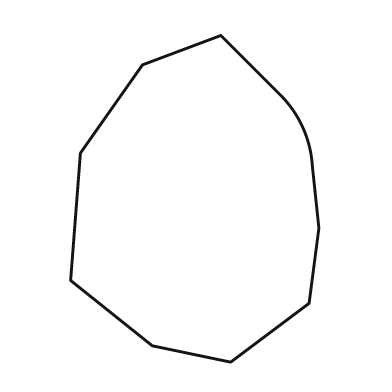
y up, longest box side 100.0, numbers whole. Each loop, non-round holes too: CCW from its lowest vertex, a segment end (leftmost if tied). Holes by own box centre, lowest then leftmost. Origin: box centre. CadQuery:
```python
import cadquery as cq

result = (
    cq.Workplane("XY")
    .moveTo(11.0, -50.0)
    .lineTo(35.0, -32.0)
    .lineTo(38.0, -9.0)
    .lineTo(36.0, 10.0)
    .threePointArc((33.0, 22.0), (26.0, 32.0))
    .lineTo(8.0, 50.0)
    .lineTo(-16.0, 41.0)
    .lineTo(-35.0, 14.0)
    .lineTo(-38.0, -25.0)
    .lineTo(-13.0, -45.0)
    .close()
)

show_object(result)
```